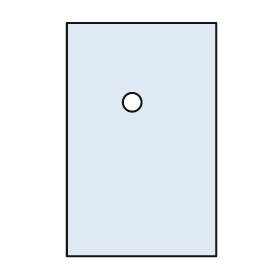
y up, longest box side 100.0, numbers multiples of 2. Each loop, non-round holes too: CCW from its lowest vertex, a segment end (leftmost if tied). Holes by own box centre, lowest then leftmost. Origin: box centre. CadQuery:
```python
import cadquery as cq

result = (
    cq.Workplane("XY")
    .moveTo(-32.0, -50.0)
    .lineTo(32.0, -50.0)
    .lineTo(32.0, 50.0)
    .lineTo(-32.0, 50.0)
    .close()
    .moveTo(-4.0, 16.0)
    .circle(4.0)
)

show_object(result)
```